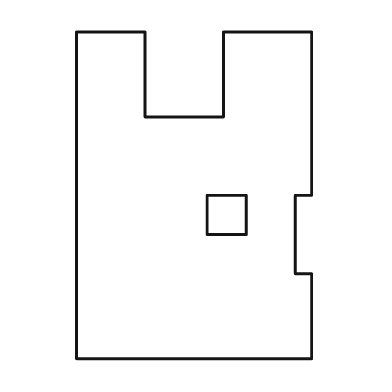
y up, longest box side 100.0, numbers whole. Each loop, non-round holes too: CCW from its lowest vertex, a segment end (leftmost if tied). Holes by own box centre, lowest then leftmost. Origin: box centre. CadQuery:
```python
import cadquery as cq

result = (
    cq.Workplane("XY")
    .moveTo(-36.0, -50.0)
    .lineTo(36.0, -50.0)
    .lineTo(36.0, -24.0)
    .lineTo(31.0, -24.0)
    .lineTo(31.0, 0.0)
    .lineTo(36.0, 0.0)
    .lineTo(36.0, 50.0)
    .lineTo(9.0, 50.0)
    .lineTo(9.0, 24.0)
    .lineTo(-15.0, 24.0)
    .lineTo(-15.0, 50.0)
    .lineTo(-36.0, 50.0)
    .close()
    .moveTo(4.0, -12.0)
    .lineTo(16.0, -12.0)
    .lineTo(16.0, 0.0)
    .lineTo(4.0, 0.0)
    .close()
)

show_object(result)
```